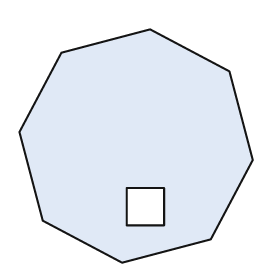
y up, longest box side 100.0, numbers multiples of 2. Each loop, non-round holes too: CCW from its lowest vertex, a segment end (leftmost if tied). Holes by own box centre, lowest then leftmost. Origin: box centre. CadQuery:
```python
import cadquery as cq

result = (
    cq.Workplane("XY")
    .moveTo(-6.0, -50.0)
    .lineTo(32.0, -40.0)
    .lineTo(50.0, -6.0)
    .lineTo(40.0, 32.0)
    .lineTo(6.0, 50.0)
    .lineTo(-32.0, 40.0)
    .lineTo(-50.0, 6.0)
    .lineTo(-40.0, -32.0)
    .close()
    .moveTo(-4.0, -34.0)
    .lineTo(12.0, -34.0)
    .lineTo(12.0, -18.0)
    .lineTo(-4.0, -18.0)
    .close()
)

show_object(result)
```